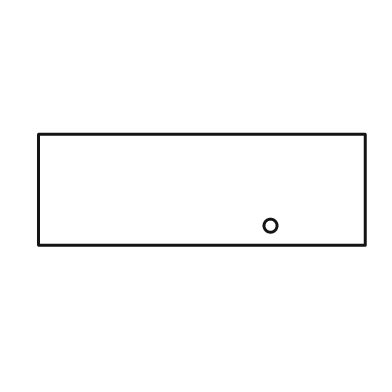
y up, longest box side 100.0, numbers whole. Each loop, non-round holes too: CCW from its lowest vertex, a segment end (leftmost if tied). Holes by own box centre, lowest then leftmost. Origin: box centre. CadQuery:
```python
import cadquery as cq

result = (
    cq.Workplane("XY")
    .moveTo(-50.0, -17.0)
    .lineTo(50.0, -17.0)
    .lineTo(50.0, 17.0)
    .lineTo(-50.0, 17.0)
    .close()
    .moveTo(21.0, -11.0)
    .circle(2.0)
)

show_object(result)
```